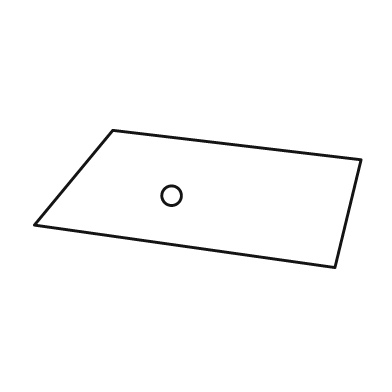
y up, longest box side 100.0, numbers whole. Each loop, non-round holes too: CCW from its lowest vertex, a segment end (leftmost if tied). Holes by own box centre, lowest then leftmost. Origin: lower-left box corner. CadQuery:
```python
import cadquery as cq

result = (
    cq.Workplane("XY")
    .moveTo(92.0, 0.0)
    .lineTo(100.0, 33.0)
    .lineTo(24.0, 42.0)
    .lineTo(0.0, 13.0)
    .close()
    .moveTo(42.0, 22.0)
    .circle(3.0)
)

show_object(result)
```